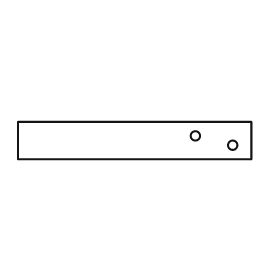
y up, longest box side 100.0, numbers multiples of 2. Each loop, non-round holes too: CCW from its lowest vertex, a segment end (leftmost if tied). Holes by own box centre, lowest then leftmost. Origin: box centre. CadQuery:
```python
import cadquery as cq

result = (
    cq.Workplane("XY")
    .moveTo(-50.0, -8.0)
    .lineTo(50.0, -8.0)
    .lineTo(50.0, 8.0)
    .lineTo(-50.0, 8.0)
    .close()
    .moveTo(42.0, -2.0)
    .circle(2.0)
    .moveTo(26.0, 2.0)
    .circle(2.0)
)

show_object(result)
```